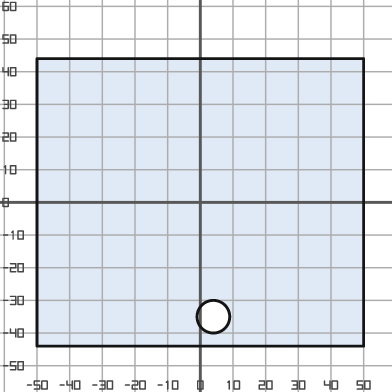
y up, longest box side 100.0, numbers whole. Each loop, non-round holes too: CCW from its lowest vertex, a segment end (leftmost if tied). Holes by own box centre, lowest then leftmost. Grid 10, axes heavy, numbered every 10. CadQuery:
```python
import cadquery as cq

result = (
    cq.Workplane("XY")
    .moveTo(-50.0, -44.0)
    .lineTo(50.0, -44.0)
    .lineTo(50.0, 44.0)
    .lineTo(-50.0, 44.0)
    .close()
    .moveTo(4.0, -35.0)
    .circle(5.0)
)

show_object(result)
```